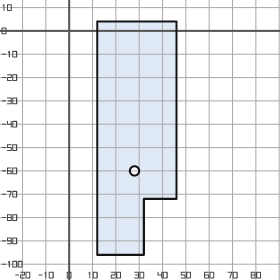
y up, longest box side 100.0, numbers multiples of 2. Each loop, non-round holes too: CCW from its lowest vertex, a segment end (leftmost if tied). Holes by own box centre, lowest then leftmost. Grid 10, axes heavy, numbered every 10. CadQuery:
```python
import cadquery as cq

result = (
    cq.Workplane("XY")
    .moveTo(12.0, -96.0)
    .lineTo(32.0, -96.0)
    .lineTo(32.0, -72.0)
    .lineTo(46.0, -72.0)
    .lineTo(46.0, 4.0)
    .lineTo(12.0, 4.0)
    .close()
    .moveTo(28.0, -60.0)
    .circle(2.0)
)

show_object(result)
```